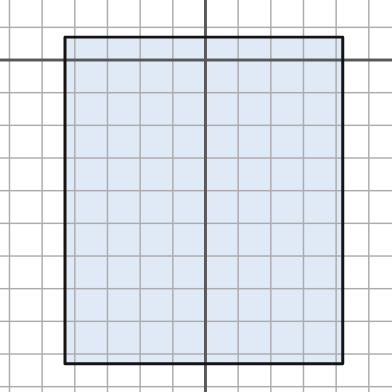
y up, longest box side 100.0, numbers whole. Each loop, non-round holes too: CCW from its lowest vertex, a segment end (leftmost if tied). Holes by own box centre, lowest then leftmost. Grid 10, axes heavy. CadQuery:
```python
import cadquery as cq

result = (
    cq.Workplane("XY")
    .moveTo(-43.0, -93.0)
    .lineTo(42.0, -93.0)
    .lineTo(42.0, 7.0)
    .lineTo(-43.0, 7.0)
    .close()
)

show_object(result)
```